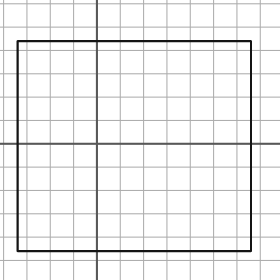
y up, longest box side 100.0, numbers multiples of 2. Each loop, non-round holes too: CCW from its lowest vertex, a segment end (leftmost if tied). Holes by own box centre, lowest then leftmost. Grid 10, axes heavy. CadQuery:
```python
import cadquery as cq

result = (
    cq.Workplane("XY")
    .moveTo(-34.0, -46.0)
    .lineTo(66.0, -46.0)
    .lineTo(66.0, 44.0)
    .lineTo(-34.0, 44.0)
    .close()
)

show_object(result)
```